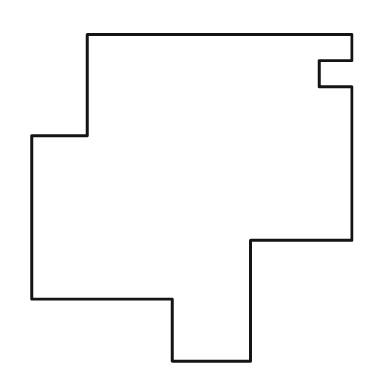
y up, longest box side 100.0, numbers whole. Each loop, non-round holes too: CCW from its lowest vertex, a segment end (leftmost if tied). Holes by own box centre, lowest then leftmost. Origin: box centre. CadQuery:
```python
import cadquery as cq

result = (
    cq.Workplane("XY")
    .moveTo(-6.0, -50.0)
    .lineTo(18.0, -50.0)
    .lineTo(18.0, -13.0)
    .lineTo(49.0, -13.0)
    .lineTo(49.0, 34.0)
    .lineTo(39.0, 34.0)
    .lineTo(39.0, 42.0)
    .lineTo(49.0, 42.0)
    .lineTo(49.0, 50.0)
    .lineTo(-32.0, 50.0)
    .lineTo(-32.0, 19.0)
    .lineTo(-49.0, 19.0)
    .lineTo(-49.0, -31.0)
    .lineTo(-6.0, -31.0)
    .close()
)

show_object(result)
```